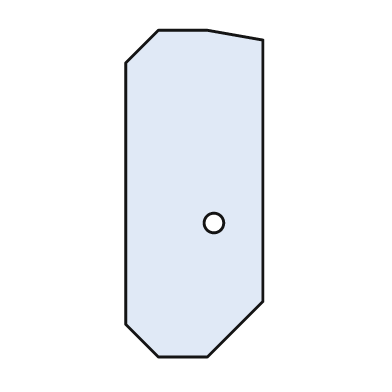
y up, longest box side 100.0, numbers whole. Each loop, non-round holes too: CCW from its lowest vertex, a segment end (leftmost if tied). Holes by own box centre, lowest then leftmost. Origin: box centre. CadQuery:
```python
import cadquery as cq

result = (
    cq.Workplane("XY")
    .moveTo(-11.0, -50.0)
    .lineTo(4.0, -50.0)
    .lineTo(21.0, -33.0)
    .lineTo(21.0, 47.0)
    .lineTo(4.0, 50.0)
    .lineTo(-11.0, 50.0)
    .lineTo(-21.0, 40.0)
    .lineTo(-21.0, -40.0)
    .close()
    .moveTo(6.0, -9.0)
    .circle(3.0)
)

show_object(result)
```